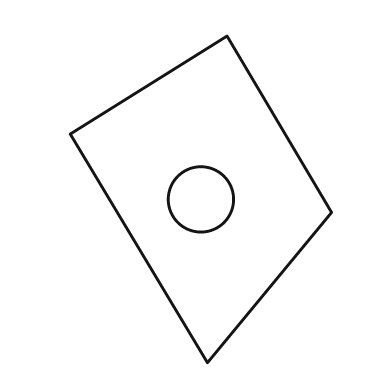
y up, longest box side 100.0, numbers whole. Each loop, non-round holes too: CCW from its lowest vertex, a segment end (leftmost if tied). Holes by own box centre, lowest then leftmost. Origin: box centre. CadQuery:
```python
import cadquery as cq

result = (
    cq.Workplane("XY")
    .moveTo(2.0, -50.0)
    .lineTo(40.0, -4.0)
    .lineTo(8.0, 50.0)
    .lineTo(-40.0, 20.0)
    .close()
    .moveTo(0.0, 0.0)
    .circle(10.0)
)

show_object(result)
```